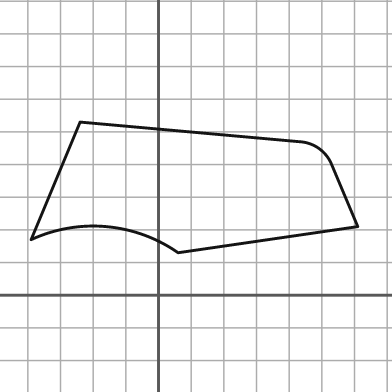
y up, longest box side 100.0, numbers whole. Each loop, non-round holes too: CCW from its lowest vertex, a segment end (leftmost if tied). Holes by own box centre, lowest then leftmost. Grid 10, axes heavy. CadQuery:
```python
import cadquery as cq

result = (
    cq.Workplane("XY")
    .moveTo(6.0, 13.0)
    .lineTo(61.0, 21.0)
    .lineTo(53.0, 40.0)
    .threePointArc((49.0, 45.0), (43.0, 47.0))
    .lineTo(-24.0, 53.0)
    .lineTo(-39.0, 17.0)
    .threePointArc((-16.0, 21.0), (6.0, 13.0))
    .close()
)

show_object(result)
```